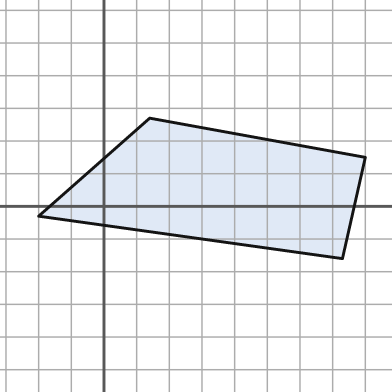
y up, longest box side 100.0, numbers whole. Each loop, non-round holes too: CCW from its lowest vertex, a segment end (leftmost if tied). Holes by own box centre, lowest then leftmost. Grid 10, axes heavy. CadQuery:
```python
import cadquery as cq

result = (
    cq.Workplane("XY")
    .moveTo(73.0, -16.0)
    .lineTo(80.0, 15.0)
    .lineTo(14.0, 27.0)
    .lineTo(-20.0, -3.0)
    .close()
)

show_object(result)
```